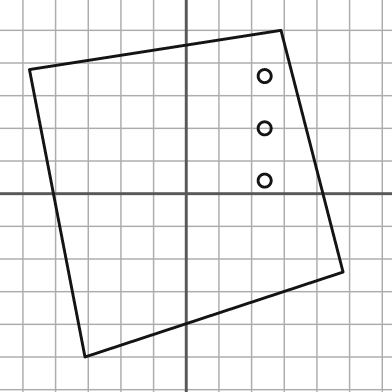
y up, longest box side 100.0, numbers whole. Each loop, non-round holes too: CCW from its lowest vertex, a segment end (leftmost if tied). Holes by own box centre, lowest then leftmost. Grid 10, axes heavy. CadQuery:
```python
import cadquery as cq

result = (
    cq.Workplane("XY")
    .moveTo(-31.0, -50.0)
    .lineTo(48.0, -24.0)
    .lineTo(29.0, 50.0)
    .lineTo(-48.0, 38.0)
    .close()
    .moveTo(24.0, 4.0)
    .circle(2.0)
    .moveTo(24.0, 20.0)
    .circle(2.0)
    .moveTo(24.0, 36.0)
    .circle(2.0)
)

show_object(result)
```